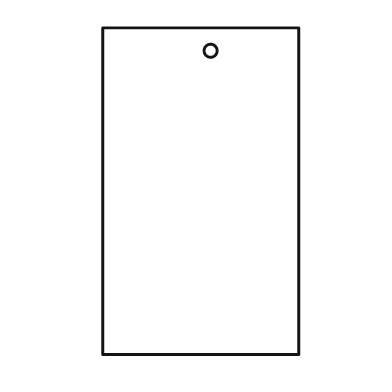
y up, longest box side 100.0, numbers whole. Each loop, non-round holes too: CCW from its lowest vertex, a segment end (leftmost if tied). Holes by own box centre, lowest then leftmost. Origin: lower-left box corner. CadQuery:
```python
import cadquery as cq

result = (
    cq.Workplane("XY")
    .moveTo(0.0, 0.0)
    .lineTo(60.0, 0.0)
    .lineTo(60.0, 100.0)
    .lineTo(0.0, 100.0)
    .close()
    .moveTo(33.0, 93.0)
    .circle(2.0)
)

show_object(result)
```